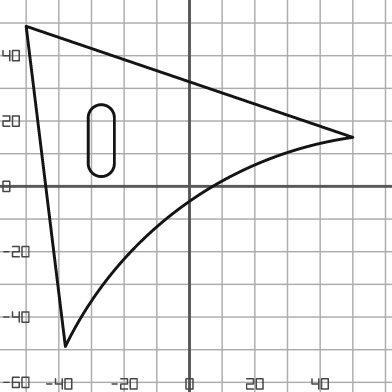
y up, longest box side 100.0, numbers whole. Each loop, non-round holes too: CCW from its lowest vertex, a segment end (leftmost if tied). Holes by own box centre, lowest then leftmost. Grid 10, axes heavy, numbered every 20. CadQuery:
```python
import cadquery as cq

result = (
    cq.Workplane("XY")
    .moveTo(-38.0, -49.0)
    .threePointArc((-2.0, -6.0), (50.0, 15.0))
    .lineTo(-50.0, 49.0)
    .close()
    .moveTo(-31.0, 7.0)
    .threePointArc((-27.0, 3.0), (-23.0, 7.0))
    .lineTo(-23.0, 21.0)
    .threePointArc((-27.0, 25.0), (-31.0, 21.0))
    .close()
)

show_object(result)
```